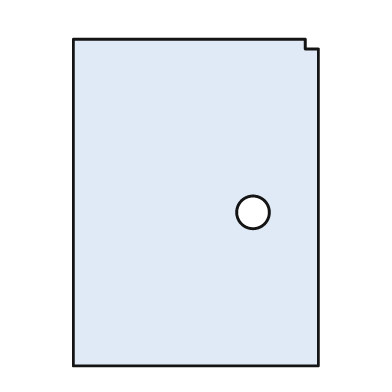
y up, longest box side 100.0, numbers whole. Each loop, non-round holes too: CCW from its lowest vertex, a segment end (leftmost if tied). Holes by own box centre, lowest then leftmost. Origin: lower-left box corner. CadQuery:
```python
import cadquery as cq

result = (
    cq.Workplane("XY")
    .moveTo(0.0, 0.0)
    .lineTo(75.0, 0.0)
    .lineTo(75.0, 97.0)
    .lineTo(71.0, 97.0)
    .lineTo(71.0, 100.0)
    .lineTo(0.0, 100.0)
    .close()
    .moveTo(55.0, 47.0)
    .circle(5.0)
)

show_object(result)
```